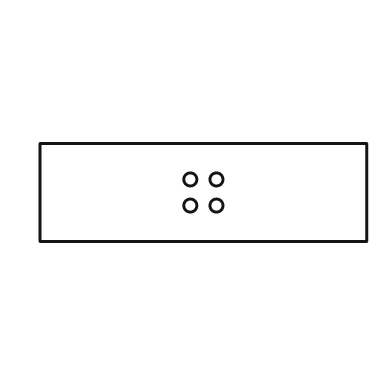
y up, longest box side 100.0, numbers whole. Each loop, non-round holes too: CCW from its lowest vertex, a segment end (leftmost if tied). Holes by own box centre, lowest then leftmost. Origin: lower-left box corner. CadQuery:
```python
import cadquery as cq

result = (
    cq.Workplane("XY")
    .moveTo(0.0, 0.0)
    .lineTo(100.0, 0.0)
    .lineTo(100.0, 30.0)
    .lineTo(0.0, 30.0)
    .close()
    .moveTo(46.0, 11.0)
    .circle(2.0)
    .moveTo(54.0, 11.0)
    .circle(2.0)
    .moveTo(46.0, 19.0)
    .circle(2.0)
    .moveTo(54.0, 19.0)
    .circle(2.0)
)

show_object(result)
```